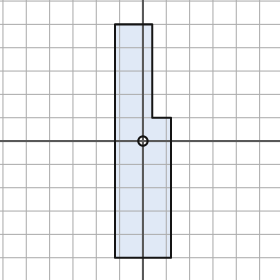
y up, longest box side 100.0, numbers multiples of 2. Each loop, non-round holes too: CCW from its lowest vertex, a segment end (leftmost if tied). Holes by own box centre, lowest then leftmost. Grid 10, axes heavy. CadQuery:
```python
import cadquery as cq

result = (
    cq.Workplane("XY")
    .moveTo(-12.0, -50.0)
    .lineTo(12.0, -50.0)
    .lineTo(12.0, 10.0)
    .lineTo(4.0, 10.0)
    .lineTo(4.0, 50.0)
    .lineTo(-12.0, 50.0)
    .close()
    .moveTo(0.0, 0.0)
    .circle(2.0)
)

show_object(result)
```